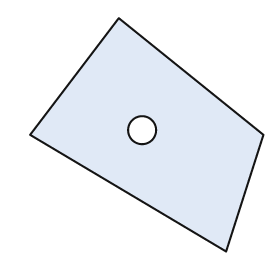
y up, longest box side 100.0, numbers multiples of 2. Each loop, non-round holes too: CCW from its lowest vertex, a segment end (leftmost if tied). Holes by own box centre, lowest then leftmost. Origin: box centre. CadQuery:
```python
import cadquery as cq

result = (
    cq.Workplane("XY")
    .moveTo(34.0, -50.0)
    .lineTo(50.0, 0.0)
    .lineTo(-12.0, 50.0)
    .lineTo(-50.0, 0.0)
    .close()
    .moveTo(-2.0, 2.0)
    .circle(6.0)
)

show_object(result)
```